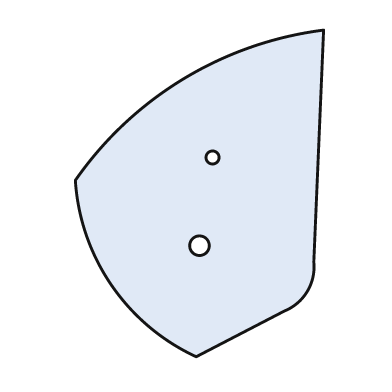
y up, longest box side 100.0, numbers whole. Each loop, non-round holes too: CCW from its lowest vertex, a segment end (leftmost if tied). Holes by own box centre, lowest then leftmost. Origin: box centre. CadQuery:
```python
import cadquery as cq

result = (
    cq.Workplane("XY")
    .moveTo(-1.0, -50.0)
    .lineTo(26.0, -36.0)
    .threePointArc((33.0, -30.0), (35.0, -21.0))
    .lineTo(38.0, 50.0)
    .threePointArc((-5.0, 35.0), (-38.0, 4.0))
    .threePointArc((-27.0, -28.0), (-1.0, -50.0))
    .close()
    .moveTo(0.0, -16.0)
    .circle(3.0)
    .moveTo(4.0, 11.0)
    .circle(2.0)
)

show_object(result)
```